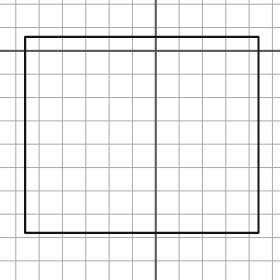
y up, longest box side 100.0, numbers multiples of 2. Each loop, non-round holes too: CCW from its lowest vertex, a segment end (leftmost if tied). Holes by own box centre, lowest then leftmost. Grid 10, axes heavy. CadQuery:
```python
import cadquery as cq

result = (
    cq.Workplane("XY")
    .moveTo(-56.0, -78.0)
    .lineTo(44.0, -78.0)
    .lineTo(44.0, 6.0)
    .lineTo(-56.0, 6.0)
    .close()
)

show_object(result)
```